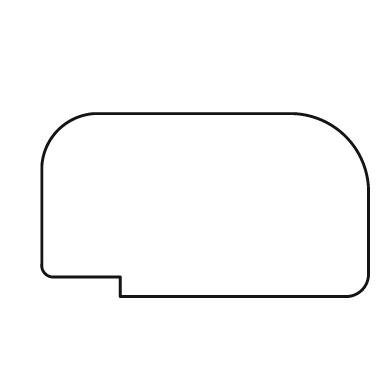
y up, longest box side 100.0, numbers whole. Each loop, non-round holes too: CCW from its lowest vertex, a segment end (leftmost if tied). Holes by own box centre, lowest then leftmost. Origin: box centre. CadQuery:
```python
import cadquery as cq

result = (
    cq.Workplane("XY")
    .moveTo(-26.0, -28.0)
    .lineTo(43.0, -28.0)
    .threePointArc((48.0, -26.0), (50.0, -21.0))
    .lineTo(50.0, 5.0)
    .threePointArc((43.0, 21.0), (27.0, 28.0))
    .lineTo(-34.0, 28.0)
    .threePointArc((-45.0, 23.0), (-50.0, 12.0))
    .lineTo(-50.0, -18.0)
    .threePointArc((-49.0, -21.0), (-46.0, -22.0))
    .lineTo(-26.0, -22.0)
    .close()
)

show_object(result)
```